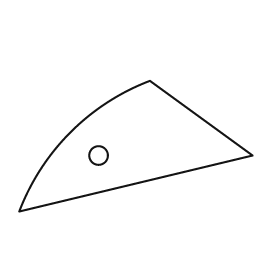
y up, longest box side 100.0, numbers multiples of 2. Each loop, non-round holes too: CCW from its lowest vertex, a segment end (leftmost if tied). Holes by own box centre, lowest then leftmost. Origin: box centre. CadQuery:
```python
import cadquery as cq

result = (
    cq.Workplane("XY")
    .moveTo(-50.0, -28.0)
    .lineTo(50.0, -4.0)
    .lineTo(6.0, 28.0)
    .threePointArc((-28.0, 6.0), (-50.0, -28.0))
    .close()
    .moveTo(-16.0, -4.0)
    .circle(4.0)
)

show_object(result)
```